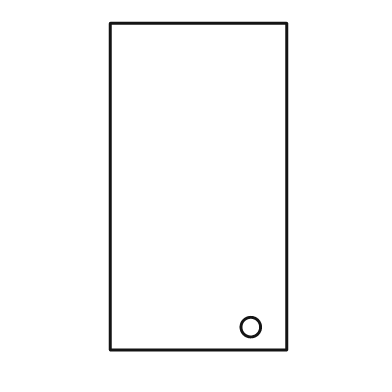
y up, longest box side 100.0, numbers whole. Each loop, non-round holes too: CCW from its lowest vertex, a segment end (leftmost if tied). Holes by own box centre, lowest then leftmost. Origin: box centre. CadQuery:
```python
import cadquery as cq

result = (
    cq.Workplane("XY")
    .moveTo(-27.0, -50.0)
    .lineTo(27.0, -50.0)
    .lineTo(27.0, 50.0)
    .lineTo(-27.0, 50.0)
    .close()
    .moveTo(16.0, -43.0)
    .circle(3.0)
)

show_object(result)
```